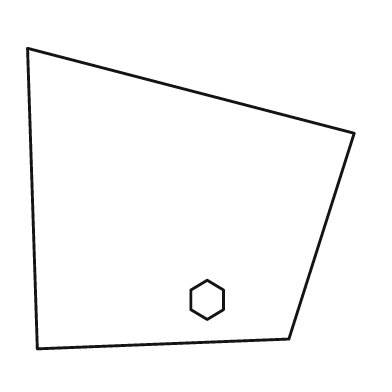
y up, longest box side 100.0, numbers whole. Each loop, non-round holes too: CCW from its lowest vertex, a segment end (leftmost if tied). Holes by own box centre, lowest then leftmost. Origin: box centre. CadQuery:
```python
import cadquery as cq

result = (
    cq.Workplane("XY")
    .moveTo(-47.0, -46.0)
    .lineTo(30.0, -43.0)
    .lineTo(50.0, 20.0)
    .lineTo(-50.0, 46.0)
    .close()
    .moveTo(5.0, -37.0)
    .lineTo(10.0, -34.0)
    .lineTo(10.0, -28.0)
    .lineTo(5.0, -25.0)
    .lineTo(0.0, -28.0)
    .lineTo(0.0, -34.0)
    .close()
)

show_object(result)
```